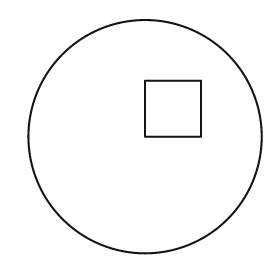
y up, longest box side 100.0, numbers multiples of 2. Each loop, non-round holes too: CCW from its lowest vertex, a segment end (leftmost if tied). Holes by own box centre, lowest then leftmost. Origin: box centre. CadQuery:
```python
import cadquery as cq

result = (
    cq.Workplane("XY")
    .moveTo(0.0, 0.0)
    .circle(50.0)
    .moveTo(0.0, 0.0)
    .lineTo(24.0, 0.0)
    .lineTo(24.0, 24.0)
    .lineTo(0.0, 24.0)
    .close()
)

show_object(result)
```